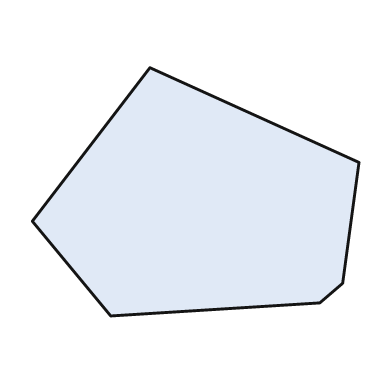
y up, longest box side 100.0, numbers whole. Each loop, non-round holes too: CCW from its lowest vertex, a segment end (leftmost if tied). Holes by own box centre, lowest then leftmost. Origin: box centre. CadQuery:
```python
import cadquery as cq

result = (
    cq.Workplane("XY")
    .moveTo(-26.0, -38.0)
    .lineTo(38.0, -34.0)
    .lineTo(45.0, -28.0)
    .lineTo(50.0, 9.0)
    .lineTo(-14.0, 38.0)
    .lineTo(-50.0, -9.0)
    .close()
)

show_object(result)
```